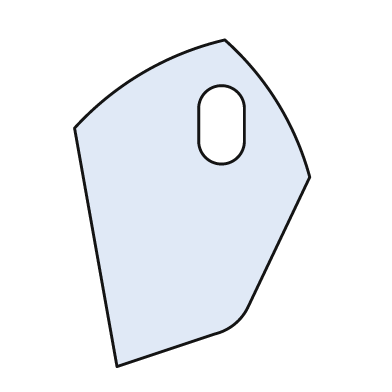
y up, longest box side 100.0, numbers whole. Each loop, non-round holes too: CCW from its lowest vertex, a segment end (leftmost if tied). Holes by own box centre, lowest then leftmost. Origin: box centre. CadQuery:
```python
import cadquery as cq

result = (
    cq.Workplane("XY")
    .moveTo(-23.0, -50.0)
    .lineTo(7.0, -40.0)
    .threePointArc((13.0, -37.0), (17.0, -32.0))
    .lineTo(36.0, 8.0)
    .threePointArc((26.0, 31.0), (10.0, 50.0))
    .threePointArc((-15.0, 40.0), (-36.0, 23.0))
    .close()
    .moveTo(2.0, 19.0)
    .threePointArc((9.0, 12.0), (16.0, 19.0))
    .lineTo(16.0, 29.0)
    .threePointArc((9.0, 36.0), (2.0, 29.0))
    .close()
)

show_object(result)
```